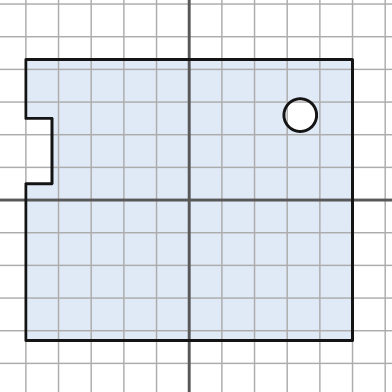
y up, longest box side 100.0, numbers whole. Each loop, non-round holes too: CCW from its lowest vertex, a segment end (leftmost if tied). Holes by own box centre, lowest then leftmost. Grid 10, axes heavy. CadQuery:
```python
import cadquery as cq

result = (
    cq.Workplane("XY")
    .moveTo(-50.0, -43.0)
    .lineTo(50.0, -43.0)
    .lineTo(50.0, 43.0)
    .lineTo(-50.0, 43.0)
    .lineTo(-50.0, 25.0)
    .lineTo(-42.0, 25.0)
    .lineTo(-42.0, 5.0)
    .lineTo(-50.0, 5.0)
    .close()
    .moveTo(34.0, 26.0)
    .circle(5.0)
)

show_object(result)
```